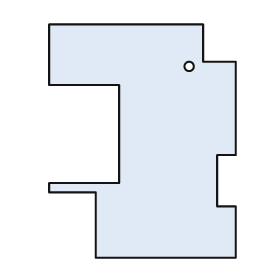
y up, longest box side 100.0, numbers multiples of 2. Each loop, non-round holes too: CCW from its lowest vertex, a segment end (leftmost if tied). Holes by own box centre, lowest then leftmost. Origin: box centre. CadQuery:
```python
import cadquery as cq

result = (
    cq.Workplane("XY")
    .moveTo(-20.0, -50.0)
    .lineTo(40.0, -50.0)
    .lineTo(40.0, -28.0)
    .lineTo(32.0, -28.0)
    .lineTo(32.0, -6.0)
    .lineTo(40.0, -6.0)
    .lineTo(40.0, 34.0)
    .lineTo(26.0, 34.0)
    .lineTo(26.0, 50.0)
    .lineTo(-40.0, 50.0)
    .lineTo(-40.0, 24.0)
    .lineTo(-10.0, 24.0)
    .lineTo(-10.0, -18.0)
    .lineTo(-40.0, -18.0)
    .lineTo(-40.0, -22.0)
    .lineTo(-20.0, -22.0)
    .close()
    .moveTo(20.0, 32.0)
    .circle(2.0)
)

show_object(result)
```